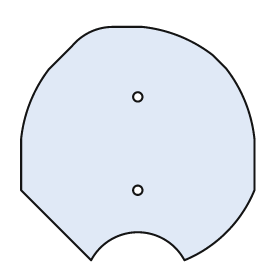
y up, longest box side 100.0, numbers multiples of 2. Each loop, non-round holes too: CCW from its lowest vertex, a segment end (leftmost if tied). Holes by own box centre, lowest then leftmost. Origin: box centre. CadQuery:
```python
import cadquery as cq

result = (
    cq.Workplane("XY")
    .moveTo(-20.0, -50.0)
    .threePointArc((0.0, -38.0), (20.0, -50.0))
    .threePointArc((38.0, -38.0), (50.0, -20.0))
    .lineTo(50.0, 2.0)
    .threePointArc((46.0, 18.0), (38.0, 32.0))
    .lineTo(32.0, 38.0)
    .threePointArc((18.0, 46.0), (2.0, 50.0))
    .lineTo(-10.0, 50.0)
    .threePointArc((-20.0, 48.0), (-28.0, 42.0))
    .lineTo(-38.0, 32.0)
    .threePointArc((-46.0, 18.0), (-50.0, 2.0))
    .lineTo(-50.0, -20.0)
    .close()
    .moveTo(0.0, -20.0)
    .circle(2.0)
    .moveTo(0.0, 20.0)
    .circle(2.0)
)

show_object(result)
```